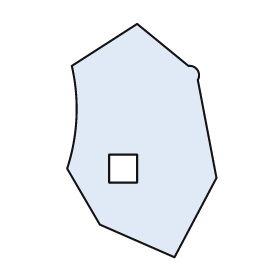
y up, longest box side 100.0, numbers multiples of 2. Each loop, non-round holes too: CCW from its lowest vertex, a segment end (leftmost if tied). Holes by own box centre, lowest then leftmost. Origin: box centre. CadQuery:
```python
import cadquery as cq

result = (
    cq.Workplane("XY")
    .moveTo(14.0, -50.0)
    .lineTo(32.0, -16.0)
    .lineTo(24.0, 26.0)
    .threePointArc((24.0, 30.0), (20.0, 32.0))
    .lineTo(-2.0, 50.0)
    .lineTo(-30.0, 32.0)
    .threePointArc((-28.0, 10.0), (-32.0, -12.0))
    .lineTo(-18.0, -36.0)
    .close()
    .moveTo(-14.0, -18.0)
    .lineTo(-2.0, -18.0)
    .lineTo(-2.0, -6.0)
    .lineTo(-14.0, -6.0)
    .close()
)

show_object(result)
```